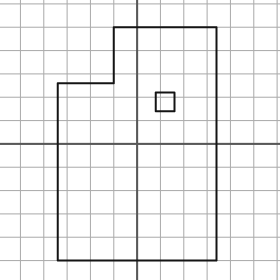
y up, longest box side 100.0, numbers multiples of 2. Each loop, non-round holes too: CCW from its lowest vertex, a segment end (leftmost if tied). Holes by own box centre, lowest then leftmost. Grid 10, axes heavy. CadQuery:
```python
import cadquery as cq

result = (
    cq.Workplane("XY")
    .moveTo(-34.0, -50.0)
    .lineTo(34.0, -50.0)
    .lineTo(34.0, 50.0)
    .lineTo(-10.0, 50.0)
    .lineTo(-10.0, 26.0)
    .lineTo(-34.0, 26.0)
    .close()
    .moveTo(8.0, 14.0)
    .lineTo(16.0, 14.0)
    .lineTo(16.0, 22.0)
    .lineTo(8.0, 22.0)
    .close()
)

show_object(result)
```